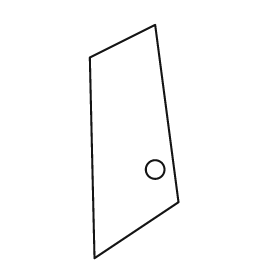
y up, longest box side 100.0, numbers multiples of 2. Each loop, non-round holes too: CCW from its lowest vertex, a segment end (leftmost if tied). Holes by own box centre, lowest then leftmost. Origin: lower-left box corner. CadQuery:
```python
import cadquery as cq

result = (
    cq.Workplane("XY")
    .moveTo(2.0, 0.0)
    .lineTo(38.0, 24.0)
    .lineTo(28.0, 100.0)
    .lineTo(0.0, 86.0)
    .close()
    .moveTo(28.0, 38.0)
    .circle(4.0)
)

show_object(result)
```